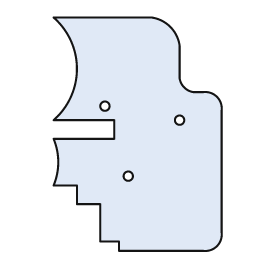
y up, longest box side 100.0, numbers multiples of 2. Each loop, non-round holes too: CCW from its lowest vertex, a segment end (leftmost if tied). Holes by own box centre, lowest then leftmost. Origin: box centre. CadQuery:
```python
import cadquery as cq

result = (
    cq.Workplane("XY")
    .moveTo(-8.0, -50.0)
    .lineTo(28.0, -50.0)
    .threePointArc((34.0, -48.0), (36.0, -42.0))
    .lineTo(36.0, 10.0)
    .threePointArc((34.0, 16.0), (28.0, 18.0))
    .lineTo(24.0, 18.0)
    .threePointArc((20.0, 20.0), (18.0, 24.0))
    .lineTo(18.0, 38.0)
    .threePointArc((14.0, 46.0), (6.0, 50.0))
    .lineTo(-36.0, 50.0)
    .threePointArc((-26.0, 28.0), (-36.0, 6.0))
    .lineTo(-10.0, 6.0)
    .lineTo(-10.0, -2.0)
    .lineTo(-36.0, -2.0)
    .threePointArc((-34.0, -12.0), (-36.0, -22.0))
    .lineTo(-26.0, -22.0)
    .lineTo(-26.0, -30.0)
    .lineTo(-16.0, -30.0)
    .lineTo(-16.0, -46.0)
    .lineTo(-8.0, -46.0)
    .close()
    .moveTo(-4.0, -18.0)
    .circle(2.0)
    .moveTo(18.0, 6.0)
    .circle(2.0)
    .moveTo(-14.0, 12.0)
    .circle(2.0)
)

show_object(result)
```